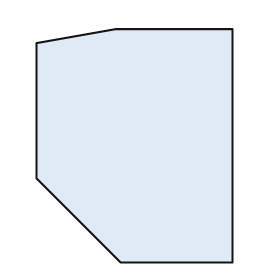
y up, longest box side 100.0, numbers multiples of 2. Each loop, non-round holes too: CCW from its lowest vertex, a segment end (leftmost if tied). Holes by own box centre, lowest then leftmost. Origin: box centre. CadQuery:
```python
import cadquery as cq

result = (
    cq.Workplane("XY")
    .moveTo(-6.0, -50.0)
    .lineTo(42.0, -50.0)
    .lineTo(42.0, 50.0)
    .lineTo(-8.0, 50.0)
    .lineTo(-42.0, 44.0)
    .lineTo(-42.0, -14.0)
    .close()
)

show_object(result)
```